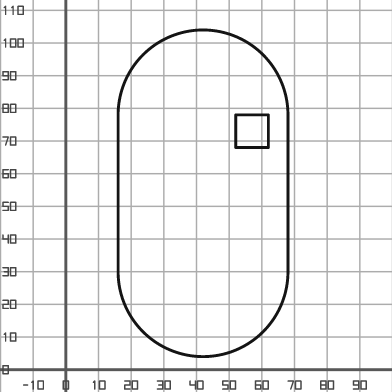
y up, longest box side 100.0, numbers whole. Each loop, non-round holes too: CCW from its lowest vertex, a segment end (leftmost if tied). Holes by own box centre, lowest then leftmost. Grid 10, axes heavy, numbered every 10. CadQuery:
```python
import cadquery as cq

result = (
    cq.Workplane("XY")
    .moveTo(16.0, 30.0)
    .threePointArc((42.0, 4.0), (68.0, 30.0))
    .lineTo(68.0, 78.0)
    .threePointArc((42.0, 104.0), (16.0, 78.0))
    .close()
    .moveTo(52.0, 68.0)
    .lineTo(62.0, 68.0)
    .lineTo(62.0, 78.0)
    .lineTo(52.0, 78.0)
    .close()
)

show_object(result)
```